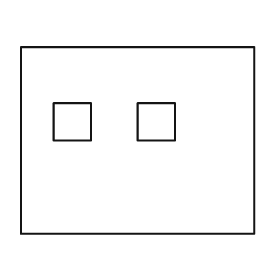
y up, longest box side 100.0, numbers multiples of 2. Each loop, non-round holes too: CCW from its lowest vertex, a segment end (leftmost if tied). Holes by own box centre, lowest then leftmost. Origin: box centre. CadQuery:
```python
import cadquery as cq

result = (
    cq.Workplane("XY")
    .moveTo(-50.0, -40.0)
    .lineTo(50.0, -40.0)
    .lineTo(50.0, 40.0)
    .lineTo(-50.0, 40.0)
    .close()
    .moveTo(-36.0, 0.0)
    .lineTo(-20.0, 0.0)
    .lineTo(-20.0, 16.0)
    .lineTo(-36.0, 16.0)
    .close()
    .moveTo(0.0, 0.0)
    .lineTo(16.0, 0.0)
    .lineTo(16.0, 16.0)
    .lineTo(0.0, 16.0)
    .close()
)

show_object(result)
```